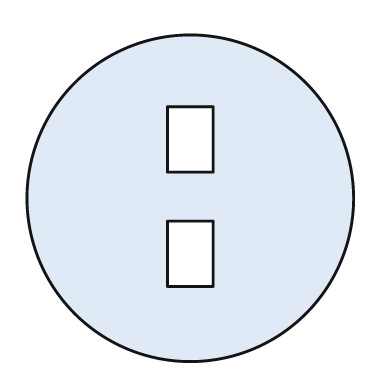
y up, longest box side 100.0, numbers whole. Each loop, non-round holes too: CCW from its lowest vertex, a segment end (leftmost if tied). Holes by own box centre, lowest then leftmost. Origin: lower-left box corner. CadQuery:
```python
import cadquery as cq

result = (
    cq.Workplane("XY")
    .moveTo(50.0, 50.0)
    .circle(50.0)
    .moveTo(43.0, 23.0)
    .lineTo(57.0, 23.0)
    .lineTo(57.0, 43.0)
    .lineTo(43.0, 43.0)
    .close()
    .moveTo(43.0, 58.0)
    .lineTo(57.0, 58.0)
    .lineTo(57.0, 78.0)
    .lineTo(43.0, 78.0)
    .close()
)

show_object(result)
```